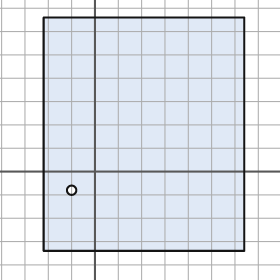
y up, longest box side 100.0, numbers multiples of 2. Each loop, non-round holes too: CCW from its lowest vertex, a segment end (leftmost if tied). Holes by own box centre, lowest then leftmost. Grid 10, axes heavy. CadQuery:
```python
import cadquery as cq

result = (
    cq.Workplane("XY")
    .moveTo(-22.0, -34.0)
    .lineTo(64.0, -34.0)
    .lineTo(64.0, 66.0)
    .lineTo(-22.0, 66.0)
    .close()
    .moveTo(-10.0, -8.0)
    .circle(2.0)
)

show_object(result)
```